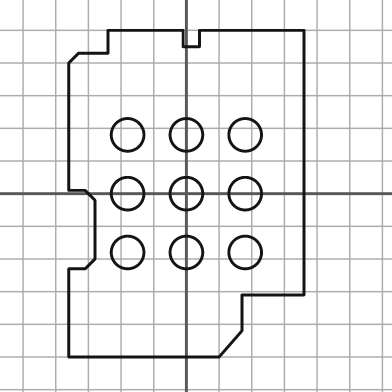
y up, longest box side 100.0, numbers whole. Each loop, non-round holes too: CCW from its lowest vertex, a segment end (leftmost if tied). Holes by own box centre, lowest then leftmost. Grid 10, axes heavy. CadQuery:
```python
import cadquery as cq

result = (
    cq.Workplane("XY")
    .moveTo(-36.0, -50.0)
    .lineTo(10.0, -50.0)
    .lineTo(17.0, -42.0)
    .lineTo(17.0, -31.0)
    .lineTo(36.0, -31.0)
    .lineTo(36.0, 50.0)
    .lineTo(4.0, 50.0)
    .lineTo(4.0, 45.0)
    .lineTo(-1.0, 45.0)
    .lineTo(-1.0, 50.0)
    .lineTo(-24.0, 50.0)
    .lineTo(-24.0, 43.0)
    .lineTo(-33.0, 43.0)
    .lineTo(-36.0, 40.0)
    .lineTo(-36.0, 1.0)
    .lineTo(-31.0, 1.0)
    .lineTo(-28.0, -2.0)
    .lineTo(-28.0, -20.0)
    .lineTo(-31.0, -23.0)
    .lineTo(-36.0, -23.0)
    .close()
    .moveTo(-18.0, -18.0)
    .circle(5.0)
    .moveTo(0.0, -18.0)
    .circle(5.0)
    .moveTo(18.0, -18.0)
    .circle(5.0)
    .moveTo(-18.0, 0.0)
    .circle(5.0)
    .moveTo(0.0, 0.0)
    .circle(5.0)
    .moveTo(18.0, 0.0)
    .circle(5.0)
    .moveTo(-18.0, 18.0)
    .circle(5.0)
    .moveTo(0.0, 18.0)
    .circle(5.0)
    .moveTo(18.0, 18.0)
    .circle(5.0)
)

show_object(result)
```